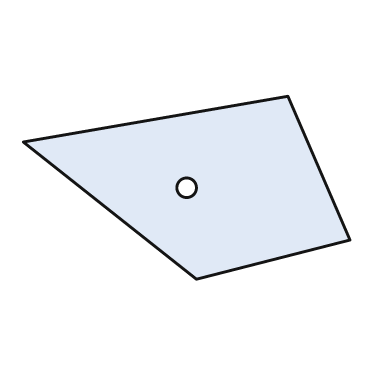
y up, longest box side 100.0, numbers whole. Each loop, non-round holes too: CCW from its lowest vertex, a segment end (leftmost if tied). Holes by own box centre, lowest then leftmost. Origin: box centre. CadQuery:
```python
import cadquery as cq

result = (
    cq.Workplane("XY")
    .moveTo(3.0, -28.0)
    .lineTo(50.0, -16.0)
    .lineTo(31.0, 28.0)
    .lineTo(-50.0, 14.0)
    .close()
    .moveTo(0.0, 0.0)
    .circle(3.0)
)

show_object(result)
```